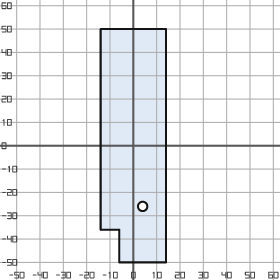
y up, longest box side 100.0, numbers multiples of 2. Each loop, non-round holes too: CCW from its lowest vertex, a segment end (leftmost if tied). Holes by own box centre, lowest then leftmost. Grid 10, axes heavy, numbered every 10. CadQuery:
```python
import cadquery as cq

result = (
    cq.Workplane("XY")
    .moveTo(-6.0, -50.0)
    .lineTo(14.0, -50.0)
    .lineTo(14.0, 50.0)
    .lineTo(-14.0, 50.0)
    .lineTo(-14.0, -36.0)
    .lineTo(-6.0, -36.0)
    .close()
    .moveTo(4.0, -26.0)
    .circle(2.0)
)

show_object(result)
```